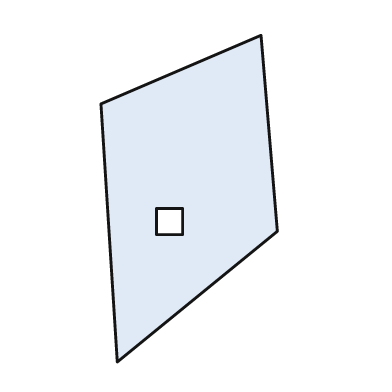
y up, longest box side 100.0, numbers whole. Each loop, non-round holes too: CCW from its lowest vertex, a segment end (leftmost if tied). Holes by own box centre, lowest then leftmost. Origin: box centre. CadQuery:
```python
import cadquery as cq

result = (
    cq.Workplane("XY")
    .moveTo(-22.0, -50.0)
    .lineTo(27.0, -10.0)
    .lineTo(22.0, 50.0)
    .lineTo(-27.0, 29.0)
    .close()
    .moveTo(-10.0, -11.0)
    .lineTo(-2.0, -11.0)
    .lineTo(-2.0, -3.0)
    .lineTo(-10.0, -3.0)
    .close()
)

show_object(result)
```